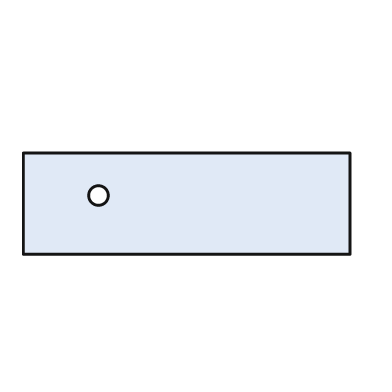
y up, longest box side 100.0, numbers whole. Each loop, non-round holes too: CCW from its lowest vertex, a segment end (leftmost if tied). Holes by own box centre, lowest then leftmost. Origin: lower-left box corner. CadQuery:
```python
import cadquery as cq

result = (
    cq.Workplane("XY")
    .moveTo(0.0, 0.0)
    .lineTo(100.0, 0.0)
    .lineTo(100.0, 31.0)
    .lineTo(0.0, 31.0)
    .close()
    .moveTo(23.0, 18.0)
    .circle(3.0)
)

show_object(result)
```